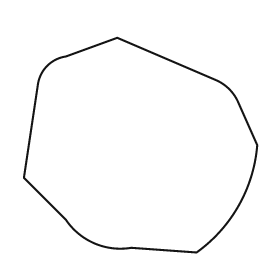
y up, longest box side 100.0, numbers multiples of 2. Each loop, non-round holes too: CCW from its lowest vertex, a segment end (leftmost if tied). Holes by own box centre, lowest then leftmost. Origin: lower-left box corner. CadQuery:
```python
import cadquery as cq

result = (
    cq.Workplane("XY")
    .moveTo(74.0, 0.0)
    .threePointArc((92.0, 20.0), (100.0, 46.0))
    .lineTo(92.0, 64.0)
    .threePointArc((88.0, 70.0), (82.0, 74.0))
    .lineTo(40.0, 92.0)
    .lineTo(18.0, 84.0)
    .threePointArc((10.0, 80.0), (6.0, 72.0))
    .lineTo(0.0, 32.0)
    .lineTo(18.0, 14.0)
    .threePointArc((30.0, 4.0), (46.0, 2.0))
    .close()
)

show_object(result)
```